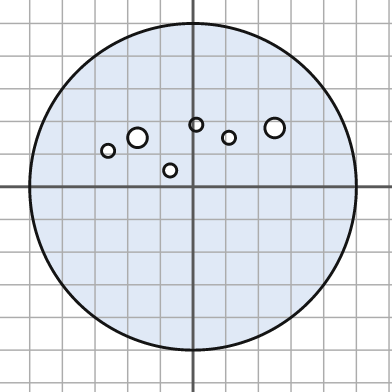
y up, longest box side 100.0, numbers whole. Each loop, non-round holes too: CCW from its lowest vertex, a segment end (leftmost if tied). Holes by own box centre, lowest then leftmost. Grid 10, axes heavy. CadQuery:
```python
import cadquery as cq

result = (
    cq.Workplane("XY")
    .moveTo(0.0, 0.0)
    .circle(50.0)
    .moveTo(-7.0, 5.0)
    .circle(2.0)
    .moveTo(-26.0, 11.0)
    .circle(2.0)
    .moveTo(-17.0, 15.0)
    .circle(3.0)
    .moveTo(11.0, 15.0)
    .circle(2.0)
    .moveTo(25.0, 18.0)
    .circle(3.0)
    .moveTo(1.0, 19.0)
    .circle(2.0)
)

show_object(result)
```